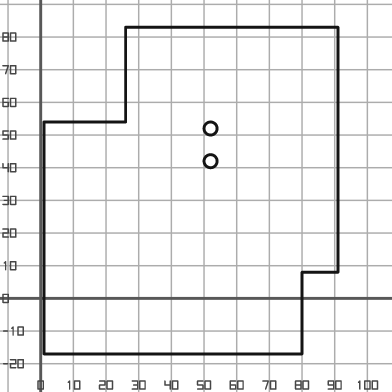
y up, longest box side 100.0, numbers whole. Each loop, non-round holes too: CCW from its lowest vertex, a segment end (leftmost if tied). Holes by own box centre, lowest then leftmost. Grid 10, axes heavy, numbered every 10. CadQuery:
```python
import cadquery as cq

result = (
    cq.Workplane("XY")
    .moveTo(1.0, -17.0)
    .lineTo(80.0, -17.0)
    .lineTo(80.0, 8.0)
    .lineTo(91.0, 8.0)
    .lineTo(91.0, 83.0)
    .lineTo(26.0, 83.0)
    .lineTo(26.0, 54.0)
    .lineTo(1.0, 54.0)
    .close()
    .moveTo(52.0, 42.0)
    .circle(2.0)
    .moveTo(52.0, 52.0)
    .circle(2.0)
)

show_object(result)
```